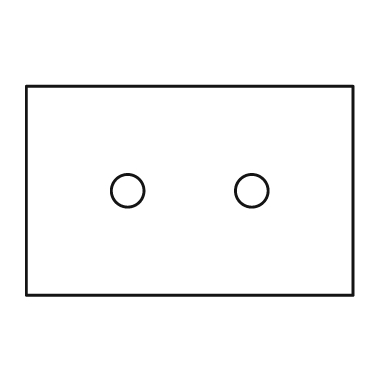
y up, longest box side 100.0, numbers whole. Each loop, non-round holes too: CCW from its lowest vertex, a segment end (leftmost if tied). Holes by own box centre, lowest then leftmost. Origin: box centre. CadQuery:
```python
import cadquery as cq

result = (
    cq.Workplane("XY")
    .moveTo(-50.0, -32.0)
    .lineTo(50.0, -32.0)
    .lineTo(50.0, 32.0)
    .lineTo(-50.0, 32.0)
    .close()
    .moveTo(-19.0, 0.0)
    .circle(5.0)
    .moveTo(19.0, 0.0)
    .circle(5.0)
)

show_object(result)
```